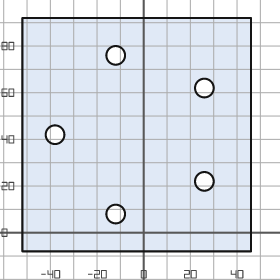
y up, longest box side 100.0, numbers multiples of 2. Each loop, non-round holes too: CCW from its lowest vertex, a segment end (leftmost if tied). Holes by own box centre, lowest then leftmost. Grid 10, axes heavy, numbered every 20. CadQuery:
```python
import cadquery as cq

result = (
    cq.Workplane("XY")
    .moveTo(-52.0, -8.0)
    .lineTo(46.0, -8.0)
    .lineTo(46.0, 92.0)
    .lineTo(-52.0, 92.0)
    .close()
    .moveTo(-12.0, 8.0)
    .circle(4.0)
    .moveTo(26.0, 22.0)
    .circle(4.0)
    .moveTo(-38.0, 42.0)
    .circle(4.0)
    .moveTo(26.0, 62.0)
    .circle(4.0)
    .moveTo(-12.0, 76.0)
    .circle(4.0)
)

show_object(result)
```